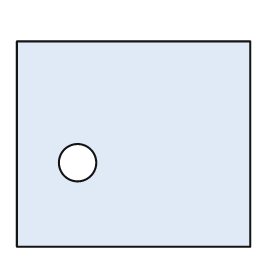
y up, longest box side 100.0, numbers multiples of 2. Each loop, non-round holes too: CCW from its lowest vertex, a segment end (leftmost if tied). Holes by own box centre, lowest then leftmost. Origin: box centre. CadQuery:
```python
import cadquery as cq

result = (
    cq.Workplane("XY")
    .moveTo(-50.0, -44.0)
    .lineTo(50.0, -44.0)
    .lineTo(50.0, 44.0)
    .lineTo(-50.0, 44.0)
    .close()
    .moveTo(-24.0, -8.0)
    .circle(8.0)
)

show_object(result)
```